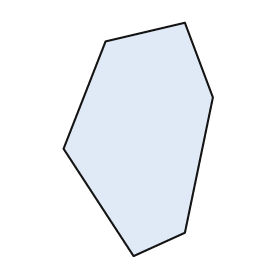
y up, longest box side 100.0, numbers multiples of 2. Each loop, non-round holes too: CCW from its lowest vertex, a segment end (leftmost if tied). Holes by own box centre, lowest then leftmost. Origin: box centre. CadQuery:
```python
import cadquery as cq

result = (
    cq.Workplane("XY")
    .moveTo(-2.0, -50.0)
    .lineTo(20.0, -40.0)
    .lineTo(32.0, 18.0)
    .lineTo(20.0, 50.0)
    .lineTo(-14.0, 42.0)
    .lineTo(-32.0, -4.0)
    .close()
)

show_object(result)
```